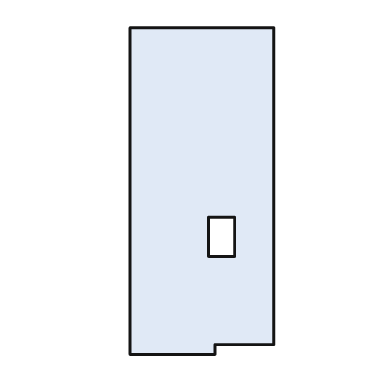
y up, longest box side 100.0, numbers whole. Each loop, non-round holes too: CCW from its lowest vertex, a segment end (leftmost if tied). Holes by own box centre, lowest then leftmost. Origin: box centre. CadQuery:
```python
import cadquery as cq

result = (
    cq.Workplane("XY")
    .moveTo(-22.0, -50.0)
    .lineTo(4.0, -50.0)
    .lineTo(4.0, -47.0)
    .lineTo(22.0, -47.0)
    .lineTo(22.0, 50.0)
    .lineTo(-22.0, 50.0)
    .close()
    .moveTo(2.0, -20.0)
    .lineTo(10.0, -20.0)
    .lineTo(10.0, -8.0)
    .lineTo(2.0, -8.0)
    .close()
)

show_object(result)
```